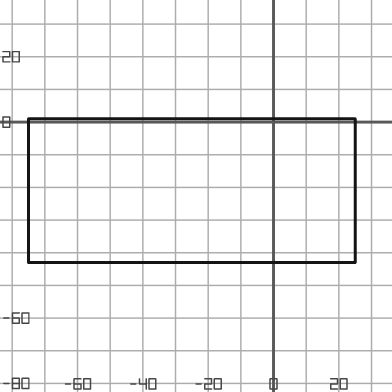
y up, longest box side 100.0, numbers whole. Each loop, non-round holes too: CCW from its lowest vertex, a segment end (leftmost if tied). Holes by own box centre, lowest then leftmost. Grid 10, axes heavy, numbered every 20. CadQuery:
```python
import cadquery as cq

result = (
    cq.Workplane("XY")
    .moveTo(-75.0, -43.0)
    .lineTo(25.0, -43.0)
    .lineTo(25.0, 1.0)
    .lineTo(-75.0, 1.0)
    .close()
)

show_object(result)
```